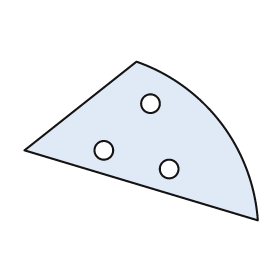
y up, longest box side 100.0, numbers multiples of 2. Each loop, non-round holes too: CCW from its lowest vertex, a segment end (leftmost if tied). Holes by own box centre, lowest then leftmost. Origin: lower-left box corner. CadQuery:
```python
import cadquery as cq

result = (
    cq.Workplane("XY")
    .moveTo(100.0, 0.0)
    .threePointArc((84.0, 42.0), (48.0, 68.0))
    .lineTo(0.0, 30.0)
    .close()
    .moveTo(62.0, 22.0)
    .circle(4.0)
    .moveTo(34.0, 30.0)
    .circle(4.0)
    .moveTo(54.0, 50.0)
    .circle(4.0)
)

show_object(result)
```